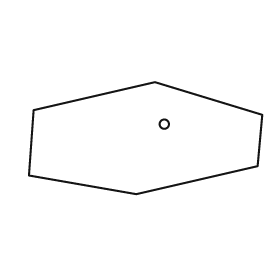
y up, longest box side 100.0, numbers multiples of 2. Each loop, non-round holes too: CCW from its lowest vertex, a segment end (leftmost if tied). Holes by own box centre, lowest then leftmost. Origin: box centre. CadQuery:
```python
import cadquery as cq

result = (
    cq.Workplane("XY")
    .moveTo(-4.0, -24.0)
    .lineTo(48.0, -12.0)
    .lineTo(50.0, 10.0)
    .lineTo(4.0, 24.0)
    .lineTo(-48.0, 12.0)
    .lineTo(-50.0, -16.0)
    .close()
    .moveTo(8.0, 6.0)
    .circle(2.0)
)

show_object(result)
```